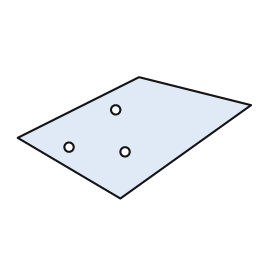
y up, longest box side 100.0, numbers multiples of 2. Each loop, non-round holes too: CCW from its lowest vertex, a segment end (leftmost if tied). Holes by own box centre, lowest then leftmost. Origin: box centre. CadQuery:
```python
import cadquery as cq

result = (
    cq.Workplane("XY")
    .moveTo(-6.0, -26.0)
    .lineTo(50.0, 14.0)
    .lineTo(2.0, 26.0)
    .lineTo(-50.0, 0.0)
    .close()
    .moveTo(-4.0, -6.0)
    .circle(2.0)
    .moveTo(-28.0, -4.0)
    .circle(2.0)
    .moveTo(-8.0, 12.0)
    .circle(2.0)
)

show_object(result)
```